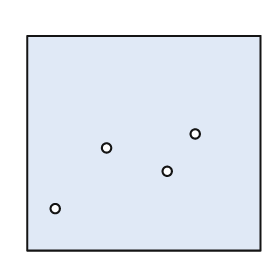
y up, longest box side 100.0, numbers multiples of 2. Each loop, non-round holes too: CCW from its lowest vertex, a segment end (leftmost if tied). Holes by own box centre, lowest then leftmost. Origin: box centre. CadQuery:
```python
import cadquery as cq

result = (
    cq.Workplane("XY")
    .moveTo(-50.0, -46.0)
    .lineTo(50.0, -46.0)
    .lineTo(50.0, 46.0)
    .lineTo(-50.0, 46.0)
    .close()
    .moveTo(-38.0, -28.0)
    .circle(2.0)
    .moveTo(10.0, -12.0)
    .circle(2.0)
    .moveTo(-16.0, -2.0)
    .circle(2.0)
    .moveTo(22.0, 4.0)
    .circle(2.0)
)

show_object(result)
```